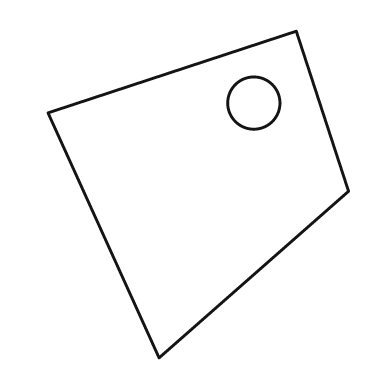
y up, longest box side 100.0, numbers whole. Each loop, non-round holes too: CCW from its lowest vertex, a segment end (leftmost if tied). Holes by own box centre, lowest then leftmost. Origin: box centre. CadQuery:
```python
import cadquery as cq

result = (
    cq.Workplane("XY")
    .moveTo(-12.0, -50.0)
    .lineTo(46.0, 1.0)
    .lineTo(30.0, 50.0)
    .lineTo(-46.0, 25.0)
    .close()
    .moveTo(17.0, 28.0)
    .circle(8.0)
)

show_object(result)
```